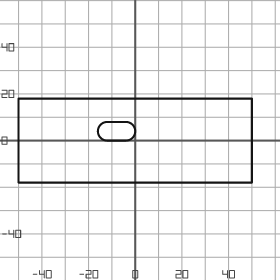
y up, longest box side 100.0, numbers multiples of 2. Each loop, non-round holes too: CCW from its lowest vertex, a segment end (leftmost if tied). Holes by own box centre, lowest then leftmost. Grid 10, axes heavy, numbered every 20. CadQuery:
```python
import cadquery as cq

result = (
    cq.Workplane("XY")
    .moveTo(-50.0, -18.0)
    .lineTo(50.0, -18.0)
    .lineTo(50.0, 18.0)
    .lineTo(-50.0, 18.0)
    .close()
    .moveTo(-12.0, 0.0)
    .lineTo(-4.0, 0.0)
    .threePointArc((0.0, 4.0), (-4.0, 8.0))
    .lineTo(-12.0, 8.0)
    .threePointArc((-16.0, 4.0), (-12.0, 0.0))
    .close()
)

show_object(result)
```